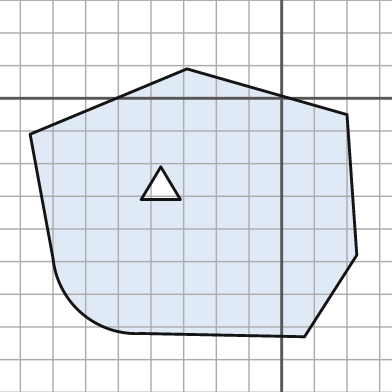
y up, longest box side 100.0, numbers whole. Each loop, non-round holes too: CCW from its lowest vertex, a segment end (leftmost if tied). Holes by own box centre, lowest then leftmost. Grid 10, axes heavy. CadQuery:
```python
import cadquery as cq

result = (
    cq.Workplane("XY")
    .moveTo(7.0, -73.0)
    .lineTo(23.0, -48.0)
    .lineTo(20.0, -5.0)
    .lineTo(-29.0, 9.0)
    .lineTo(-77.0, -11.0)
    .lineTo(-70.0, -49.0)
    .threePointArc((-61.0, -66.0), (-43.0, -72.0))
    .close()
    .moveTo(-43.0, -31.0)
    .lineTo(-31.0, -31.0)
    .lineTo(-37.0, -21.0)
    .close()
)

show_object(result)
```